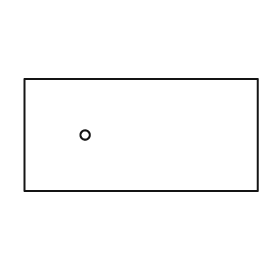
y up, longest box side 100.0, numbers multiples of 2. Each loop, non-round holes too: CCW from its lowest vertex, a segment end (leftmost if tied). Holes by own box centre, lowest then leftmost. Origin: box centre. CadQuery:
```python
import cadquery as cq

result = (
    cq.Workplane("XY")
    .moveTo(-50.0, -24.0)
    .lineTo(50.0, -24.0)
    .lineTo(50.0, 24.0)
    .lineTo(-50.0, 24.0)
    .close()
    .moveTo(-24.0, 0.0)
    .circle(2.0)
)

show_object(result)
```